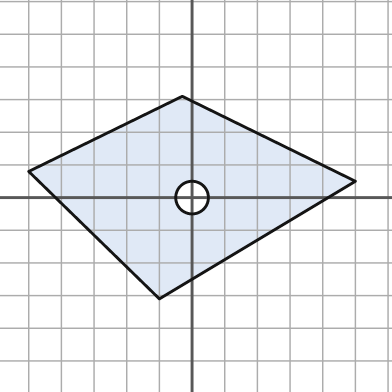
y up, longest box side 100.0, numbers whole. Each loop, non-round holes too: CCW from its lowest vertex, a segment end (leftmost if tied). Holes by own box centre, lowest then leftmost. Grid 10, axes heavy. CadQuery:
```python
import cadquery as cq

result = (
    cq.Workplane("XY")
    .moveTo(-10.0, -31.0)
    .lineTo(50.0, 5.0)
    .lineTo(-3.0, 31.0)
    .lineTo(-50.0, 8.0)
    .close()
    .moveTo(0.0, 0.0)
    .circle(5.0)
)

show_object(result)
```